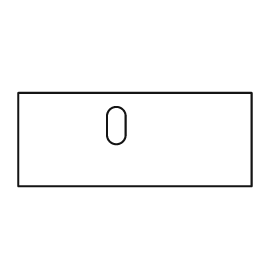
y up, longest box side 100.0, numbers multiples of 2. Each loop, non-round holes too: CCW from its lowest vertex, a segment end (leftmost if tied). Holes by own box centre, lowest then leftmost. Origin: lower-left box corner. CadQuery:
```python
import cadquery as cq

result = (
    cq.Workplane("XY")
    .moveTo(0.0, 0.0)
    .lineTo(100.0, 0.0)
    .lineTo(100.0, 40.0)
    .lineTo(0.0, 40.0)
    .close()
    .moveTo(38.0, 22.0)
    .threePointArc((42.0, 18.0), (46.0, 22.0))
    .lineTo(46.0, 30.0)
    .threePointArc((42.0, 34.0), (38.0, 30.0))
    .close()
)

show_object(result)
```